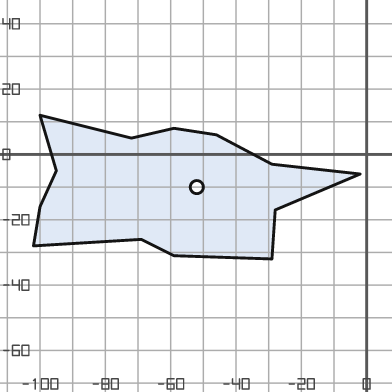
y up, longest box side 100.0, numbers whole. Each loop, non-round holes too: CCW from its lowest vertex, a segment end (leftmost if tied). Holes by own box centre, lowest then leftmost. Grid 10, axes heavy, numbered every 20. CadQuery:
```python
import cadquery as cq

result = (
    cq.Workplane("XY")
    .moveTo(-29.0, -32.0)
    .lineTo(-28.0, -17.0)
    .lineTo(-2.0, -6.0)
    .lineTo(-29.0, -3.0)
    .lineTo(-46.0, 6.0)
    .lineTo(-59.0, 8.0)
    .lineTo(-72.0, 5.0)
    .lineTo(-100.0, 12.0)
    .lineTo(-95.0, -5.0)
    .lineTo(-100.0, -16.0)
    .lineTo(-102.0, -28.0)
    .lineTo(-69.0, -26.0)
    .lineTo(-59.0, -31.0)
    .close()
    .moveTo(-52.0, -10.0)
    .circle(2.0)
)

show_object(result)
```